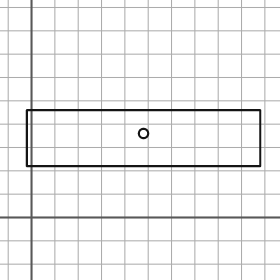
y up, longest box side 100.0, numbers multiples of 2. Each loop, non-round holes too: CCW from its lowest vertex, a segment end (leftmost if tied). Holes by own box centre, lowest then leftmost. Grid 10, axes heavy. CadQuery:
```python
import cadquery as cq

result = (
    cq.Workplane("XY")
    .moveTo(-2.0, 22.0)
    .lineTo(98.0, 22.0)
    .lineTo(98.0, 46.0)
    .lineTo(-2.0, 46.0)
    .close()
    .moveTo(48.0, 36.0)
    .circle(2.0)
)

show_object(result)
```